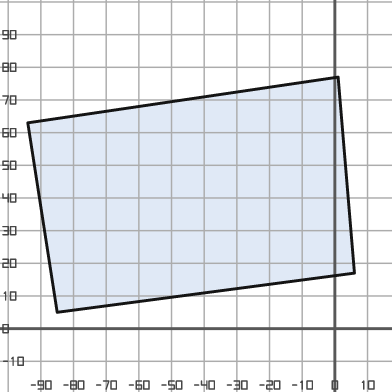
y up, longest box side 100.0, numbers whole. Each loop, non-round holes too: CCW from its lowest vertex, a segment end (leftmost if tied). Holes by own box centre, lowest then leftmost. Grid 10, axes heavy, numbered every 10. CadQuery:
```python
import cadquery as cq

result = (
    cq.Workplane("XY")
    .moveTo(-85.0, 5.0)
    .lineTo(6.0, 17.0)
    .lineTo(1.0, 77.0)
    .lineTo(-94.0, 63.0)
    .close()
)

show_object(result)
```